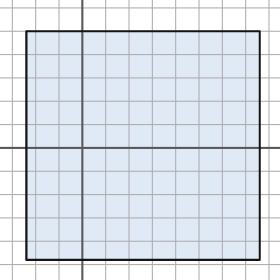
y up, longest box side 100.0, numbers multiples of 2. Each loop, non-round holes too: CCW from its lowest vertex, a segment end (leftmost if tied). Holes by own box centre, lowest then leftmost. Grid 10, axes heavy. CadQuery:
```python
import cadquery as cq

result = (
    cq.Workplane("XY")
    .moveTo(-24.0, -48.0)
    .lineTo(76.0, -48.0)
    .lineTo(76.0, 50.0)
    .lineTo(-24.0, 50.0)
    .close()
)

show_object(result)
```